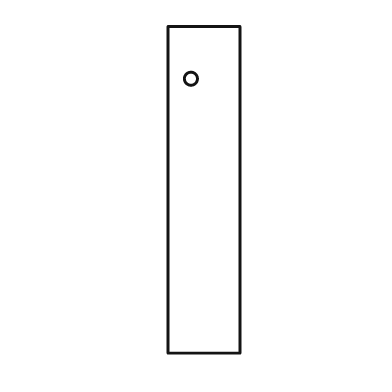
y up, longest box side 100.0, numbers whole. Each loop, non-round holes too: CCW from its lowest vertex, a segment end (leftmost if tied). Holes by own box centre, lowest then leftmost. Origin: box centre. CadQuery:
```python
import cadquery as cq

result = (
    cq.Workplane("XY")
    .moveTo(-11.0, -50.0)
    .lineTo(11.0, -50.0)
    .lineTo(11.0, 50.0)
    .lineTo(-11.0, 50.0)
    .close()
    .moveTo(-4.0, 34.0)
    .circle(2.0)
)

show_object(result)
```